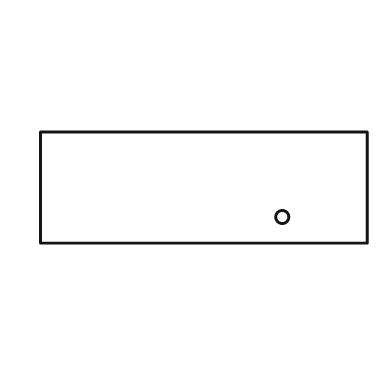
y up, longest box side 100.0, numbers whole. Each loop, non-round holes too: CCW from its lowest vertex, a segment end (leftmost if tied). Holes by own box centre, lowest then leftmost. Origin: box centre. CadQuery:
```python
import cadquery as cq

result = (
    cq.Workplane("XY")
    .moveTo(-50.0, -17.0)
    .lineTo(50.0, -17.0)
    .lineTo(50.0, 17.0)
    .lineTo(-50.0, 17.0)
    .close()
    .moveTo(24.0, -9.0)
    .circle(2.0)
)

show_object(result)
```